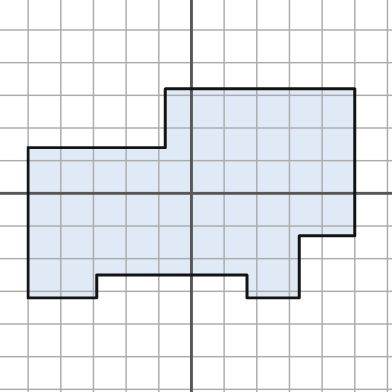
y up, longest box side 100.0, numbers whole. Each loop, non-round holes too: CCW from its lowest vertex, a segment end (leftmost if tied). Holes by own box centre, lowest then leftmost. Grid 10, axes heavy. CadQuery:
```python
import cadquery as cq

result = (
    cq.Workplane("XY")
    .moveTo(-50.0, -32.0)
    .lineTo(-29.0, -32.0)
    .lineTo(-29.0, -25.0)
    .lineTo(17.0, -25.0)
    .lineTo(17.0, -32.0)
    .lineTo(33.0, -32.0)
    .lineTo(33.0, -13.0)
    .lineTo(50.0, -13.0)
    .lineTo(50.0, 32.0)
    .lineTo(-8.0, 32.0)
    .lineTo(-8.0, 14.0)
    .lineTo(-50.0, 14.0)
    .close()
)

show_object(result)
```